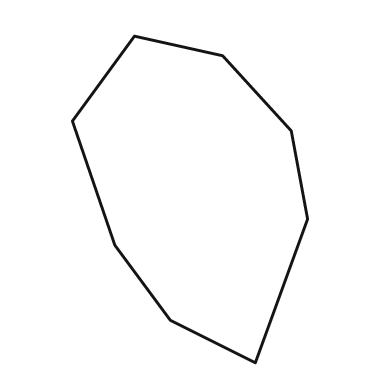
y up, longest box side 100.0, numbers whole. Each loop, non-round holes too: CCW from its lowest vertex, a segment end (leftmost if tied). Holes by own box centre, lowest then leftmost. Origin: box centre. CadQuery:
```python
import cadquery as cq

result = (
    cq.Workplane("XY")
    .moveTo(20.0, -50.0)
    .lineTo(36.0, -6.0)
    .lineTo(31.0, 21.0)
    .lineTo(10.0, 44.0)
    .lineTo(-17.0, 50.0)
    .lineTo(-36.0, 24.0)
    .lineTo(-23.0, -14.0)
    .lineTo(-6.0, -37.0)
    .close()
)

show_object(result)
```